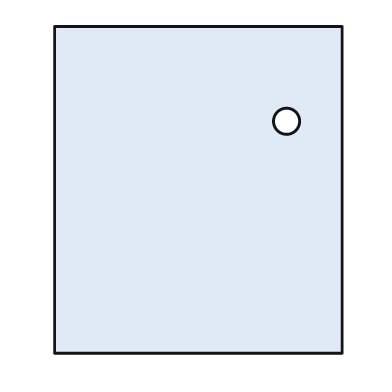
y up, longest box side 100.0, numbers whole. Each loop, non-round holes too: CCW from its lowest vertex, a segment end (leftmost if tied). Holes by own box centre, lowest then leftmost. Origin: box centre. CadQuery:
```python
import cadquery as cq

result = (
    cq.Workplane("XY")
    .moveTo(-44.0, -50.0)
    .lineTo(44.0, -50.0)
    .lineTo(44.0, 50.0)
    .lineTo(-44.0, 50.0)
    .close()
    .moveTo(27.0, 21.0)
    .circle(4.0)
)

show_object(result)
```